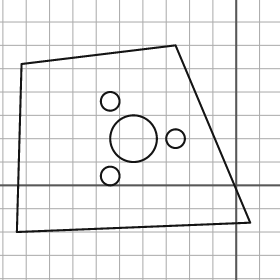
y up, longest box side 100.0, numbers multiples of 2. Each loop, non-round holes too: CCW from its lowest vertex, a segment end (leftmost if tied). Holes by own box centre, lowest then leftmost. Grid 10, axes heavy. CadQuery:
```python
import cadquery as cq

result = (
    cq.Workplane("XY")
    .moveTo(-94.0, -20.0)
    .lineTo(6.0, -16.0)
    .lineTo(-26.0, 60.0)
    .lineTo(-92.0, 52.0)
    .close()
    .moveTo(-54.0, 4.0)
    .circle(4.0)
    .moveTo(-44.0, 20.0)
    .circle(10.0)
    .moveTo(-26.0, 20.0)
    .circle(4.0)
    .moveTo(-54.0, 36.0)
    .circle(4.0)
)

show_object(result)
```